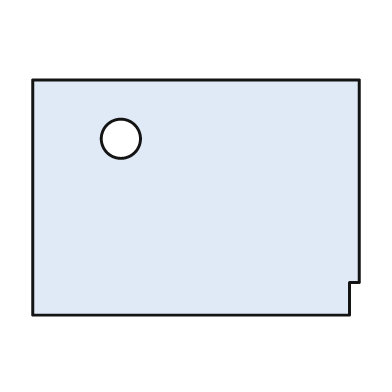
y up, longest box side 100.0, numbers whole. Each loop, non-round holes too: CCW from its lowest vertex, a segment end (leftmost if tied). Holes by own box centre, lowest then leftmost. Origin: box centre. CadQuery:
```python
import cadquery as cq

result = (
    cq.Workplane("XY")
    .moveTo(-50.0, -36.0)
    .lineTo(47.0, -36.0)
    .lineTo(47.0, -26.0)
    .lineTo(50.0, -26.0)
    .lineTo(50.0, 36.0)
    .lineTo(-50.0, 36.0)
    .close()
    .moveTo(-23.0, 18.0)
    .circle(6.0)
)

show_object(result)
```